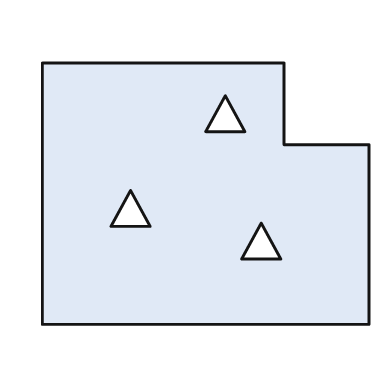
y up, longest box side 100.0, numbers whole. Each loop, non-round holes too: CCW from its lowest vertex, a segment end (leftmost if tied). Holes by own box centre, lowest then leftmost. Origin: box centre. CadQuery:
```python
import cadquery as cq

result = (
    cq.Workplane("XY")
    .moveTo(-50.0, -40.0)
    .lineTo(50.0, -40.0)
    .lineTo(50.0, 15.0)
    .lineTo(24.0, 15.0)
    .lineTo(24.0, 40.0)
    .lineTo(-50.0, 40.0)
    .close()
    .moveTo(11.0, -20.0)
    .lineTo(23.0, -20.0)
    .lineTo(17.0, -9.0)
    .close()
    .moveTo(-29.0, -10.0)
    .lineTo(-17.0, -10.0)
    .lineTo(-23.0, 1.0)
    .close()
    .moveTo(0.0, 19.0)
    .lineTo(12.0, 19.0)
    .lineTo(6.0, 30.0)
    .close()
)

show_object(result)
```